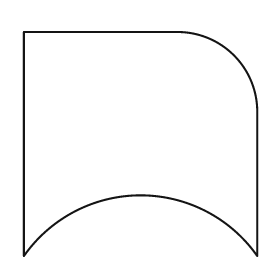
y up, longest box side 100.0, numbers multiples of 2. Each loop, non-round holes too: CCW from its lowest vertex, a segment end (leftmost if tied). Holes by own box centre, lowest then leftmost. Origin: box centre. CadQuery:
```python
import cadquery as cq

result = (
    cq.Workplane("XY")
    .moveTo(-50.0, -48.0)
    .threePointArc((0.0, -22.0), (50.0, -48.0))
    .lineTo(50.0, 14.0)
    .threePointArc((40.0, 38.0), (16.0, 48.0))
    .lineTo(-50.0, 48.0)
    .close()
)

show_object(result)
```